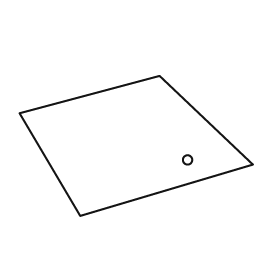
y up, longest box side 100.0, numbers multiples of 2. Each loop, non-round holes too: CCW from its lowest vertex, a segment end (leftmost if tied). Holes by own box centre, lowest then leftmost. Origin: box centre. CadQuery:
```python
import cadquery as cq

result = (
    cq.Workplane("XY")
    .moveTo(-24.0, -30.0)
    .lineTo(50.0, -8.0)
    .lineTo(10.0, 30.0)
    .lineTo(-50.0, 14.0)
    .close()
    .moveTo(22.0, -6.0)
    .circle(2.0)
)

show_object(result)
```